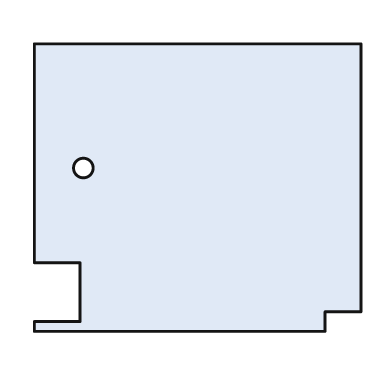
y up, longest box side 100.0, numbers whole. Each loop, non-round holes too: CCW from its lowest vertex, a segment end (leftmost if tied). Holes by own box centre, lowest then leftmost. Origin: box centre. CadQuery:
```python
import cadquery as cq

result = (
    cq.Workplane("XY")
    .moveTo(-50.0, -44.0)
    .lineTo(39.0, -44.0)
    .lineTo(39.0, -38.0)
    .lineTo(50.0, -38.0)
    .lineTo(50.0, 44.0)
    .lineTo(-50.0, 44.0)
    .lineTo(-50.0, -23.0)
    .lineTo(-36.0, -23.0)
    .lineTo(-36.0, -41.0)
    .lineTo(-50.0, -41.0)
    .close()
    .moveTo(-35.0, 6.0)
    .circle(3.0)
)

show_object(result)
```